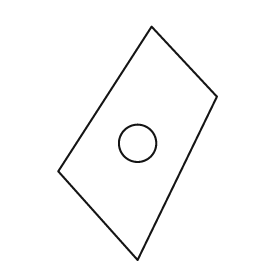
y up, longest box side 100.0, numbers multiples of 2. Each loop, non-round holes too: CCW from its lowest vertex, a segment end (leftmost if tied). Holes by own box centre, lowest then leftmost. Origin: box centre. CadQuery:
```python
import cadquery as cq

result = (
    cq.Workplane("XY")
    .moveTo(0.0, -50.0)
    .lineTo(34.0, 20.0)
    .lineTo(6.0, 50.0)
    .lineTo(-34.0, -12.0)
    .close()
    .moveTo(0.0, 0.0)
    .circle(8.0)
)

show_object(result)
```